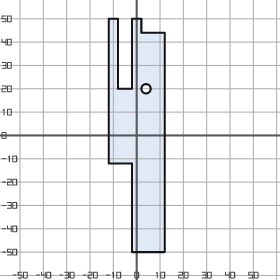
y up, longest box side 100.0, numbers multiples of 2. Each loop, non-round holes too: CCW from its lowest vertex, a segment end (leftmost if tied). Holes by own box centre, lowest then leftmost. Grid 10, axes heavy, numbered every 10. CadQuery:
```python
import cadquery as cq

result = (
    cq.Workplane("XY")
    .moveTo(-2.0, -50.0)
    .lineTo(12.0, -50.0)
    .lineTo(12.0, 44.0)
    .lineTo(2.0, 44.0)
    .lineTo(2.0, 50.0)
    .lineTo(-2.0, 50.0)
    .lineTo(-2.0, 20.0)
    .lineTo(-8.0, 20.0)
    .lineTo(-8.0, 50.0)
    .lineTo(-12.0, 50.0)
    .lineTo(-12.0, -12.0)
    .lineTo(-2.0, -12.0)
    .close()
    .moveTo(4.0, 20.0)
    .circle(2.0)
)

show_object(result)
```